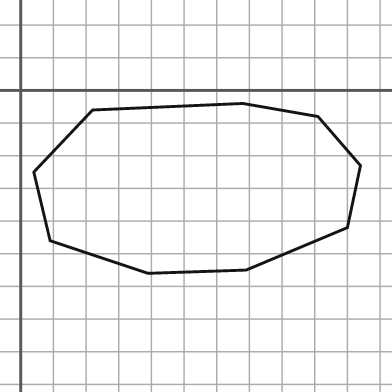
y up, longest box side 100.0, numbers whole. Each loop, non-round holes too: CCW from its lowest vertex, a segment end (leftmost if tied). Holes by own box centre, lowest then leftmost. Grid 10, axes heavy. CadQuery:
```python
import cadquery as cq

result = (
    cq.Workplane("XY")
    .moveTo(39.0, -56.0)
    .lineTo(69.0, -55.0)
    .lineTo(100.0, -42.0)
    .lineTo(104.0, -23.0)
    .lineTo(91.0, -8.0)
    .lineTo(68.0, -4.0)
    .lineTo(22.0, -6.0)
    .lineTo(4.0, -25.0)
    .lineTo(9.0, -46.0)
    .close()
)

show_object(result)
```